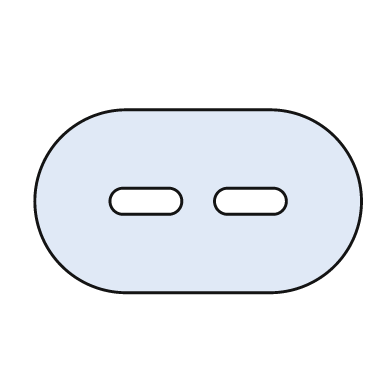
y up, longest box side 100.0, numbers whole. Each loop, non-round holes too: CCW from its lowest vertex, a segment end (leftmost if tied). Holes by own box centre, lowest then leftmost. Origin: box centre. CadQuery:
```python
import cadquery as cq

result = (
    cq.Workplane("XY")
    .moveTo(-22.0, -28.0)
    .lineTo(22.0, -28.0)
    .threePointArc((50.0, 0.0), (22.0, 28.0))
    .lineTo(-22.0, 28.0)
    .threePointArc((-50.0, 0.0), (-22.0, -28.0))
    .close()
    .moveTo(-23.0, -4.0)
    .lineTo(-9.0, -4.0)
    .threePointArc((-5.0, 0.0), (-9.0, 4.0))
    .lineTo(-23.0, 4.0)
    .threePointArc((-27.0, 0.0), (-23.0, -4.0))
    .close()
    .moveTo(9.0, -4.0)
    .lineTo(23.0, -4.0)
    .threePointArc((27.0, 0.0), (23.0, 4.0))
    .lineTo(9.0, 4.0)
    .threePointArc((5.0, 0.0), (9.0, -4.0))
    .close()
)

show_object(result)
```